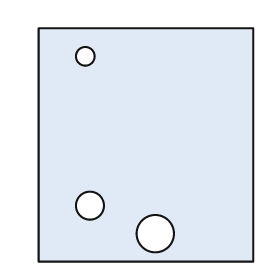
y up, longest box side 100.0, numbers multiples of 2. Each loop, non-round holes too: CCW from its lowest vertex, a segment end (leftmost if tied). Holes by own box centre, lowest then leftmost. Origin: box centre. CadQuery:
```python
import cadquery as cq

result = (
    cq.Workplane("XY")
    .moveTo(-46.0, -50.0)
    .lineTo(46.0, -50.0)
    .lineTo(46.0, 50.0)
    .lineTo(-46.0, 50.0)
    .close()
    .moveTo(4.0, -38.0)
    .circle(8.0)
    .moveTo(-24.0, -26.0)
    .circle(6.0)
    .moveTo(-26.0, 38.0)
    .circle(4.0)
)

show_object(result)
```